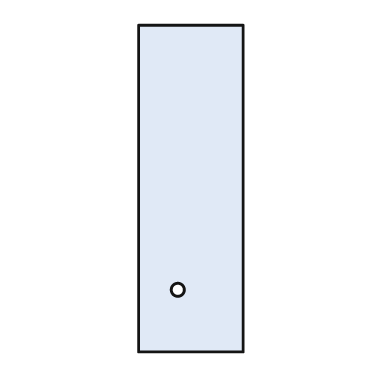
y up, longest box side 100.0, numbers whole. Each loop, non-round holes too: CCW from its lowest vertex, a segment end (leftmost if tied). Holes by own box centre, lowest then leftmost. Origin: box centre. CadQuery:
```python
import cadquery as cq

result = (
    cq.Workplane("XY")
    .moveTo(-16.0, -50.0)
    .lineTo(16.0, -50.0)
    .lineTo(16.0, 50.0)
    .lineTo(-16.0, 50.0)
    .close()
    .moveTo(-4.0, -31.0)
    .circle(2.0)
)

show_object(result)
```